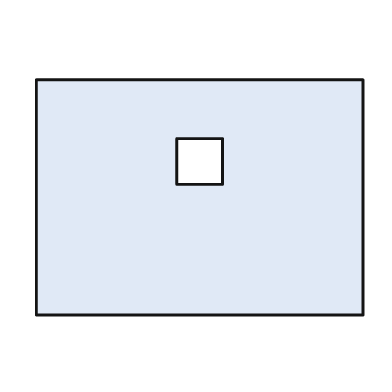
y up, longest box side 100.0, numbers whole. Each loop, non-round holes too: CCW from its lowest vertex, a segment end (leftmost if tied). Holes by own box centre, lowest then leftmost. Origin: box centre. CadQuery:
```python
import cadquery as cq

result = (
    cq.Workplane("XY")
    .moveTo(-50.0, -36.0)
    .lineTo(50.0, -36.0)
    .lineTo(50.0, 36.0)
    .lineTo(-50.0, 36.0)
    .close()
    .moveTo(-7.0, 4.0)
    .lineTo(7.0, 4.0)
    .lineTo(7.0, 18.0)
    .lineTo(-7.0, 18.0)
    .close()
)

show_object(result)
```